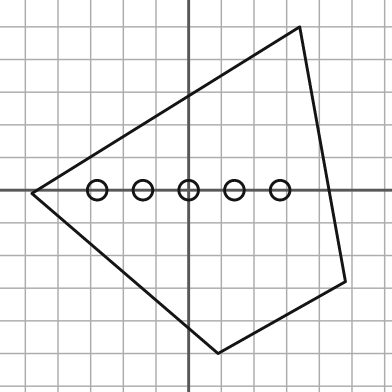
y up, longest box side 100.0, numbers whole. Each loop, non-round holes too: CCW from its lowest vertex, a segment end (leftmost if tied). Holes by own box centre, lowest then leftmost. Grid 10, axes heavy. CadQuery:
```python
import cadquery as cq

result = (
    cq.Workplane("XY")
    .moveTo(9.0, -50.0)
    .lineTo(48.0, -28.0)
    .lineTo(34.0, 50.0)
    .lineTo(-48.0, -1.0)
    .close()
    .moveTo(-28.0, 0.0)
    .circle(3.0)
    .moveTo(-14.0, 0.0)
    .circle(3.0)
    .moveTo(0.0, 0.0)
    .circle(3.0)
    .moveTo(14.0, 0.0)
    .circle(3.0)
    .moveTo(28.0, 0.0)
    .circle(3.0)
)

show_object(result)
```